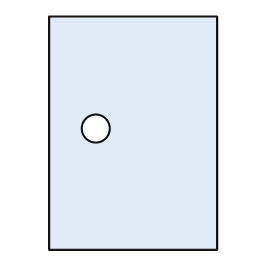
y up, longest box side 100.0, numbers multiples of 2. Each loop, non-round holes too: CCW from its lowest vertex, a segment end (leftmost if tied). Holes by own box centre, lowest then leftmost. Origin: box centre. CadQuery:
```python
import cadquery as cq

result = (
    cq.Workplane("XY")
    .moveTo(-36.0, -50.0)
    .lineTo(36.0, -50.0)
    .lineTo(36.0, 50.0)
    .lineTo(-36.0, 50.0)
    .close()
    .moveTo(-16.0, 2.0)
    .circle(6.0)
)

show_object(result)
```